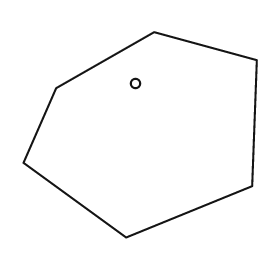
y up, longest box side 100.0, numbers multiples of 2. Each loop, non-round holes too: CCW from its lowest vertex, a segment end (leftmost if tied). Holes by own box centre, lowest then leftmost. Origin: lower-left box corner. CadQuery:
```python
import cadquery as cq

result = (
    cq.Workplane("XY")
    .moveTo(44.0, 0.0)
    .lineTo(98.0, 22.0)
    .lineTo(100.0, 76.0)
    .lineTo(56.0, 88.0)
    .lineTo(14.0, 64.0)
    .lineTo(0.0, 32.0)
    .close()
    .moveTo(48.0, 66.0)
    .circle(2.0)
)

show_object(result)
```